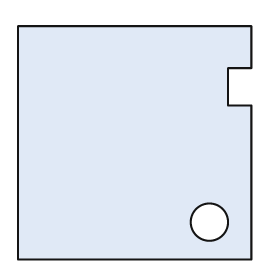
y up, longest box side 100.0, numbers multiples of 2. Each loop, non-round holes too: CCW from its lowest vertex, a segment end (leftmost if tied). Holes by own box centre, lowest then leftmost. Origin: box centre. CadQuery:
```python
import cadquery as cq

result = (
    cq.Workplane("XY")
    .moveTo(-50.0, -50.0)
    .lineTo(50.0, -50.0)
    .lineTo(50.0, 16.0)
    .lineTo(40.0, 16.0)
    .lineTo(40.0, 32.0)
    .lineTo(50.0, 32.0)
    .lineTo(50.0, 50.0)
    .lineTo(-50.0, 50.0)
    .close()
    .moveTo(32.0, -34.0)
    .circle(8.0)
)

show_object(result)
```